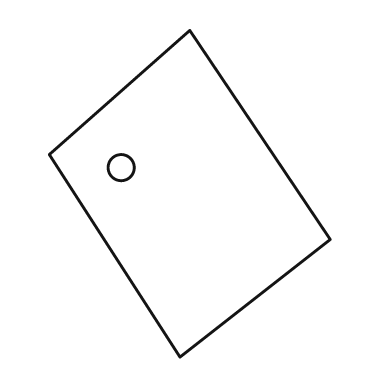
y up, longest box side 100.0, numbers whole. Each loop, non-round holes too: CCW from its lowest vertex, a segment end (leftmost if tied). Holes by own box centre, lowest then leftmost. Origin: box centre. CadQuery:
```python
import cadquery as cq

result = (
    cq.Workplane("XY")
    .moveTo(-3.0, -50.0)
    .lineTo(43.0, -14.0)
    .lineTo(0.0, 50.0)
    .lineTo(-43.0, 12.0)
    .close()
    .moveTo(-21.0, 8.0)
    .circle(4.0)
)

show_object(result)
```